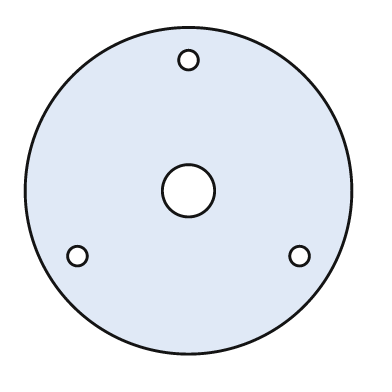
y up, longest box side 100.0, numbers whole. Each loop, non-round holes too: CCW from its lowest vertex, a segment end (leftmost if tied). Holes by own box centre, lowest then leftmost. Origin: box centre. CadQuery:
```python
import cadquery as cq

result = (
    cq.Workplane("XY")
    .moveTo(0.0, 0.0)
    .circle(50.0)
    .moveTo(-34.0, -20.0)
    .circle(3.0)
    .moveTo(34.0, -20.0)
    .circle(3.0)
    .moveTo(0.0, 0.0)
    .circle(8.0)
    .moveTo(0.0, 40.0)
    .circle(3.0)
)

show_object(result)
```